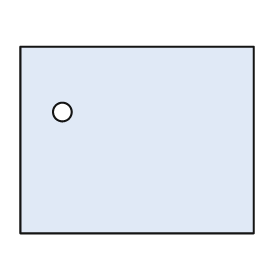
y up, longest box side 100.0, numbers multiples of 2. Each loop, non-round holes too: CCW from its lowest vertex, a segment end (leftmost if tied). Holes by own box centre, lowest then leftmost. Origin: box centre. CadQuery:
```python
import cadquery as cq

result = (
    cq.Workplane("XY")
    .moveTo(-50.0, -40.0)
    .lineTo(50.0, -40.0)
    .lineTo(50.0, 40.0)
    .lineTo(-50.0, 40.0)
    .close()
    .moveTo(-32.0, 12.0)
    .circle(4.0)
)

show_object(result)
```